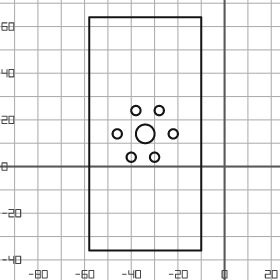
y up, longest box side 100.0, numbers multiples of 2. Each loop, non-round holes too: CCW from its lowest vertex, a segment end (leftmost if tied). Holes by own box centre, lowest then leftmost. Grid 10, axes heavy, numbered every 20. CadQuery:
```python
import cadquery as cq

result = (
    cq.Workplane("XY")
    .moveTo(-58.0, -36.0)
    .lineTo(-10.0, -36.0)
    .lineTo(-10.0, 64.0)
    .lineTo(-58.0, 64.0)
    .close()
    .moveTo(-40.0, 4.0)
    .circle(2.0)
    .moveTo(-30.0, 4.0)
    .circle(2.0)
    .moveTo(-46.0, 14.0)
    .circle(2.0)
    .moveTo(-34.0, 14.0)
    .circle(4.0)
    .moveTo(-22.0, 14.0)
    .circle(2.0)
    .moveTo(-38.0, 24.0)
    .circle(2.0)
    .moveTo(-28.0, 24.0)
    .circle(2.0)
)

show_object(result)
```